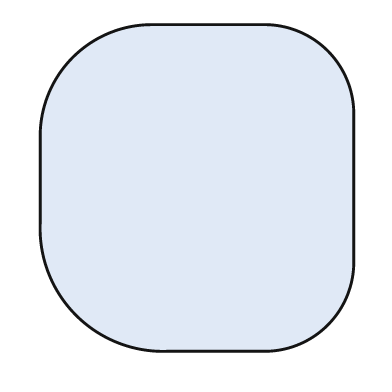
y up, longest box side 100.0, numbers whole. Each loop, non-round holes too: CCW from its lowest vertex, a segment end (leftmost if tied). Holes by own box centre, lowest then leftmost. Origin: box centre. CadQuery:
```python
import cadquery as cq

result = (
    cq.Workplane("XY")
    .moveTo(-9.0, -50.0)
    .lineTo(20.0, -50.0)
    .threePointArc((40.0, -42.0), (48.0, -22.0))
    .lineTo(48.0, 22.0)
    .threePointArc((40.0, 42.0), (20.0, 50.0))
    .lineTo(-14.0, 50.0)
    .threePointArc((-38.0, 40.0), (-48.0, 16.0))
    .lineTo(-48.0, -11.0)
    .threePointArc((-37.0, -39.0), (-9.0, -50.0))
    .close()
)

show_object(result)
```